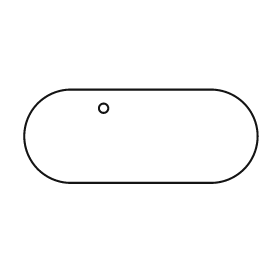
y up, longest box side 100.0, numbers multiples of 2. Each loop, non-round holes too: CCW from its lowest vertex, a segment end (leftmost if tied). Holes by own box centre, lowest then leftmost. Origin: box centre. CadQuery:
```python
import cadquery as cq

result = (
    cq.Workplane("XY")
    .moveTo(-30.0, -20.0)
    .lineTo(30.0, -20.0)
    .threePointArc((50.0, 0.0), (30.0, 20.0))
    .lineTo(-30.0, 20.0)
    .threePointArc((-50.0, 0.0), (-30.0, -20.0))
    .close()
    .moveTo(-16.0, 12.0)
    .circle(2.0)
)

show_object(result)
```